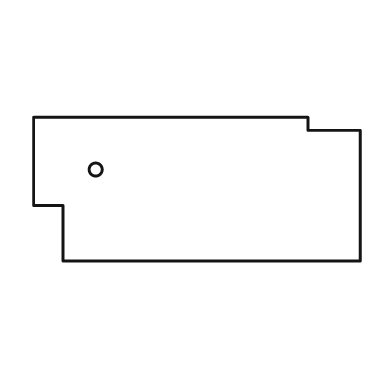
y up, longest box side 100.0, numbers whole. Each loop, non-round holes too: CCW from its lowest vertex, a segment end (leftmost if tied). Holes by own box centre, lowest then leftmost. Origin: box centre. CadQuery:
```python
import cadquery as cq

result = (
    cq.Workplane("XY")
    .moveTo(-41.0, -22.0)
    .lineTo(50.0, -22.0)
    .lineTo(50.0, 18.0)
    .lineTo(34.0, 18.0)
    .lineTo(34.0, 22.0)
    .lineTo(-50.0, 22.0)
    .lineTo(-50.0, -5.0)
    .lineTo(-41.0, -5.0)
    .close()
    .moveTo(-31.0, 6.0)
    .circle(2.0)
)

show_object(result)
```